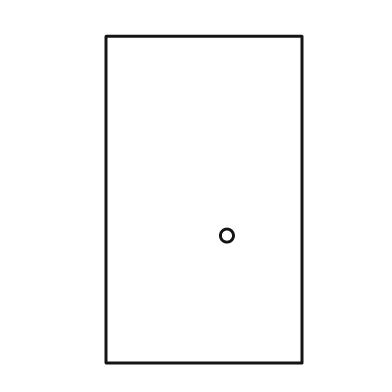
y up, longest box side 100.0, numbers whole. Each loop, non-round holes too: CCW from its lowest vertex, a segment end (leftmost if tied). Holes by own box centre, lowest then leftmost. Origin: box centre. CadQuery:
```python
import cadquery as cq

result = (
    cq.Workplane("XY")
    .moveTo(-30.0, -50.0)
    .lineTo(30.0, -50.0)
    .lineTo(30.0, 50.0)
    .lineTo(-30.0, 50.0)
    .close()
    .moveTo(7.0, -11.0)
    .circle(2.0)
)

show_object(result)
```